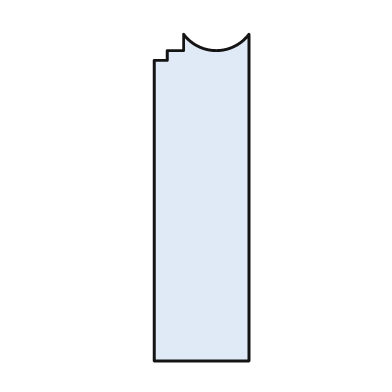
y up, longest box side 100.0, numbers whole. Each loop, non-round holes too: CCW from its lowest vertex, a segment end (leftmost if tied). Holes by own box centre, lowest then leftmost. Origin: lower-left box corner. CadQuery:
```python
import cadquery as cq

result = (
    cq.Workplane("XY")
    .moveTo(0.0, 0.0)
    .lineTo(29.0, 0.0)
    .lineTo(29.0, 100.0)
    .threePointArc((19.0, 95.0), (9.0, 100.0))
    .lineTo(9.0, 95.0)
    .lineTo(4.0, 95.0)
    .lineTo(4.0, 92.0)
    .lineTo(0.0, 92.0)
    .close()
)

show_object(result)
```